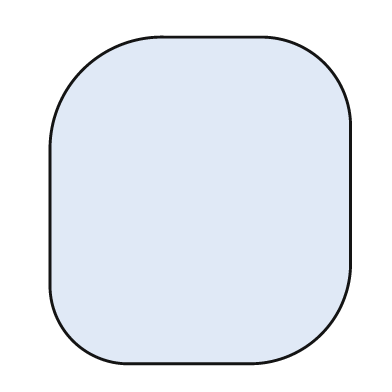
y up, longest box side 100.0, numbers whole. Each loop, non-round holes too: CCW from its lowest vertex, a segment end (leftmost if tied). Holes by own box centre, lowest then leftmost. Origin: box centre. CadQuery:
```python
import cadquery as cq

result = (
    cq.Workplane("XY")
    .moveTo(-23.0, -50.0)
    .lineTo(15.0, -50.0)
    .threePointArc((37.0, -41.0), (46.0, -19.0))
    .lineTo(46.0, 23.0)
    .threePointArc((38.0, 42.0), (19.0, 50.0))
    .lineTo(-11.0, 50.0)
    .threePointArc((-36.0, 40.0), (-46.0, 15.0))
    .lineTo(-46.0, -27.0)
    .threePointArc((-39.0, -43.0), (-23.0, -50.0))
    .close()
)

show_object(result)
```